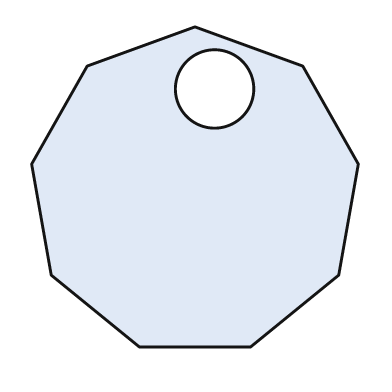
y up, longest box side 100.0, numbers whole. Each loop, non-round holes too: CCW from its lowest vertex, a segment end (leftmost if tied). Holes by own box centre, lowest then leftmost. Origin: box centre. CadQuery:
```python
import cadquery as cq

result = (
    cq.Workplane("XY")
    .moveTo(-17.0, -49.0)
    .lineTo(17.0, -49.0)
    .lineTo(44.0, -27.0)
    .lineTo(50.0, 7.0)
    .lineTo(33.0, 37.0)
    .lineTo(0.0, 49.0)
    .lineTo(-33.0, 37.0)
    .lineTo(-50.0, 7.0)
    .lineTo(-44.0, -27.0)
    .close()
    .moveTo(6.0, 30.0)
    .circle(12.0)
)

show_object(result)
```